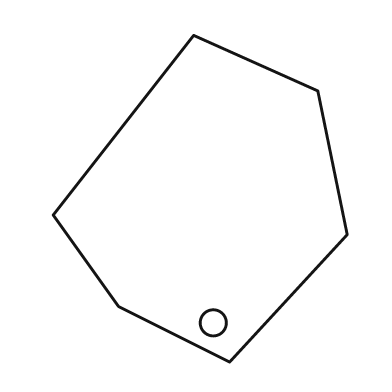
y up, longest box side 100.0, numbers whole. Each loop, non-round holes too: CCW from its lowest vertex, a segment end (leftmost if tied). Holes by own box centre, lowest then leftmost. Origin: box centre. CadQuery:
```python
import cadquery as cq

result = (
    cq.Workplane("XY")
    .moveTo(9.0, -50.0)
    .lineTo(45.0, -11.0)
    .lineTo(36.0, 33.0)
    .lineTo(-2.0, 50.0)
    .lineTo(-45.0, -5.0)
    .lineTo(-25.0, -33.0)
    .close()
    .moveTo(4.0, -38.0)
    .circle(4.0)
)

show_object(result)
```